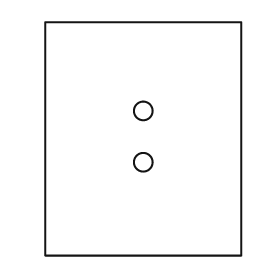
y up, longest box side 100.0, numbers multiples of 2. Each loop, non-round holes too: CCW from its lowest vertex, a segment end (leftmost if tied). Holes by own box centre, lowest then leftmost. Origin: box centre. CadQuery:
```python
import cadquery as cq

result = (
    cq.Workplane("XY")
    .moveTo(-42.0, -50.0)
    .lineTo(42.0, -50.0)
    .lineTo(42.0, 50.0)
    .lineTo(-42.0, 50.0)
    .close()
    .moveTo(0.0, -10.0)
    .circle(4.0)
    .moveTo(0.0, 12.0)
    .circle(4.0)
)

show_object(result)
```